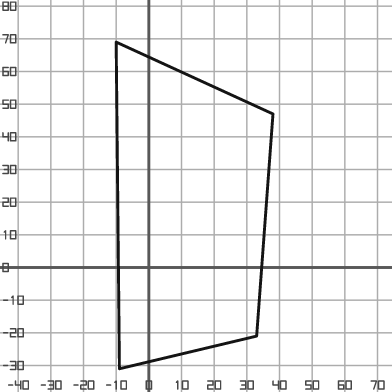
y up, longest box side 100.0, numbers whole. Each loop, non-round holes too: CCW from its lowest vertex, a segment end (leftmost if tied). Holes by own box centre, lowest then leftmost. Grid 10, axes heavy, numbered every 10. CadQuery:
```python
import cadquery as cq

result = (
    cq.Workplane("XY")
    .moveTo(-9.0, -31.0)
    .lineTo(33.0, -21.0)
    .lineTo(38.0, 47.0)
    .lineTo(-10.0, 69.0)
    .close()
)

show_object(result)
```